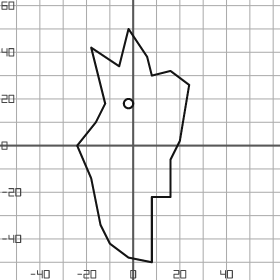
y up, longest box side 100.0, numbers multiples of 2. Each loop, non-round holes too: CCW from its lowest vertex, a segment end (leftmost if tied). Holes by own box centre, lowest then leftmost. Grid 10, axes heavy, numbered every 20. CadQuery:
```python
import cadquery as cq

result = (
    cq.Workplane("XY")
    .moveTo(8.0, -50.0)
    .lineTo(8.0, -22.0)
    .lineTo(16.0, -22.0)
    .lineTo(16.0, -6.0)
    .lineTo(20.0, 2.0)
    .lineTo(24.0, 26.0)
    .lineTo(16.0, 32.0)
    .lineTo(8.0, 30.0)
    .lineTo(6.0, 38.0)
    .lineTo(-2.0, 50.0)
    .lineTo(-6.0, 34.0)
    .lineTo(-18.0, 42.0)
    .lineTo(-12.0, 18.0)
    .lineTo(-16.0, 10.0)
    .lineTo(-24.0, 0.0)
    .lineTo(-18.0, -14.0)
    .lineTo(-14.0, -34.0)
    .lineTo(-10.0, -42.0)
    .lineTo(-2.0, -48.0)
    .close()
    .moveTo(-2.0, 18.0)
    .circle(2.0)
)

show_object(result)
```